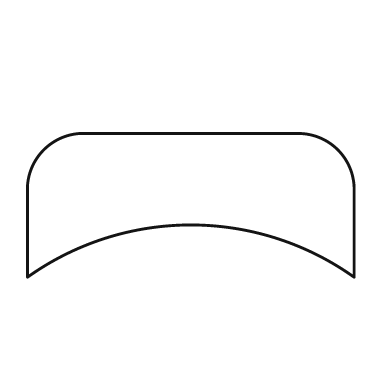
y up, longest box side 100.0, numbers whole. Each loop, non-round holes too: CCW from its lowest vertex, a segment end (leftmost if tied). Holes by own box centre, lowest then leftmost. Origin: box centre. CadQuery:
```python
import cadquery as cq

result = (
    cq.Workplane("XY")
    .moveTo(-50.0, -22.0)
    .threePointArc((0.0, -6.0), (50.0, -22.0))
    .lineTo(50.0, 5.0)
    .threePointArc((45.0, 17.0), (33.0, 22.0))
    .lineTo(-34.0, 22.0)
    .threePointArc((-45.0, 17.0), (-50.0, 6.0))
    .close()
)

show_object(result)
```